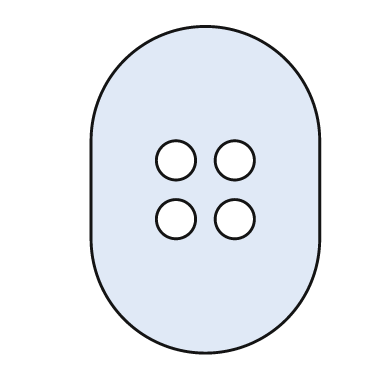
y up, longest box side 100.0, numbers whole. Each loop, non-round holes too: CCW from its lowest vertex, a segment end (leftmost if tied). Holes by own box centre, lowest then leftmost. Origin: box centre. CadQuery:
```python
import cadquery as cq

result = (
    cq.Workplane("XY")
    .moveTo(-35.0, -15.0)
    .threePointArc((0.0, -50.0), (35.0, -15.0))
    .lineTo(35.0, 15.0)
    .threePointArc((0.0, 50.0), (-35.0, 15.0))
    .close()
    .moveTo(-9.0, -9.0)
    .circle(6.0)
    .moveTo(9.0, -9.0)
    .circle(6.0)
    .moveTo(-9.0, 9.0)
    .circle(6.0)
    .moveTo(9.0, 9.0)
    .circle(6.0)
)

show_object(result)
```